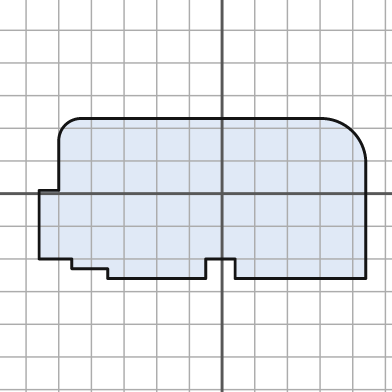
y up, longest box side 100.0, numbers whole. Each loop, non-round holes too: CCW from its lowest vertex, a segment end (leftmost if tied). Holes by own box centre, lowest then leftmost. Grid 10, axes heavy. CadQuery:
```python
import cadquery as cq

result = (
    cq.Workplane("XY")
    .moveTo(-35.0, -26.0)
    .lineTo(-5.0, -26.0)
    .lineTo(-5.0, -20.0)
    .lineTo(4.0, -20.0)
    .lineTo(4.0, -26.0)
    .lineTo(44.0, -26.0)
    .lineTo(44.0, 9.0)
    .threePointArc((40.0, 19.0), (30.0, 23.0))
    .lineTo(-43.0, 23.0)
    .threePointArc((-48.0, 21.0), (-50.0, 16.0))
    .lineTo(-50.0, 1.0)
    .lineTo(-56.0, 1.0)
    .lineTo(-56.0, -20.0)
    .lineTo(-46.0, -20.0)
    .lineTo(-46.0, -23.0)
    .lineTo(-35.0, -23.0)
    .close()
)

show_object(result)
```